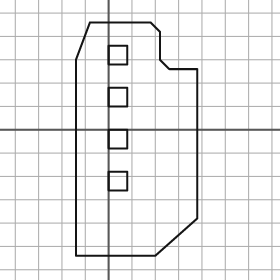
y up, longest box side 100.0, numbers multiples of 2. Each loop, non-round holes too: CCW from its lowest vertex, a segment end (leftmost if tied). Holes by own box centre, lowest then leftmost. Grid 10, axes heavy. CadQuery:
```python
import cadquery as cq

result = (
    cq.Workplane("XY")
    .moveTo(-14.0, -54.0)
    .lineTo(20.0, -54.0)
    .lineTo(38.0, -38.0)
    .lineTo(38.0, 26.0)
    .lineTo(26.0, 26.0)
    .lineTo(22.0, 30.0)
    .lineTo(22.0, 42.0)
    .lineTo(18.0, 46.0)
    .lineTo(-8.0, 46.0)
    .lineTo(-14.0, 30.0)
    .close()
    .moveTo(0.0, -26.0)
    .lineTo(8.0, -26.0)
    .lineTo(8.0, -18.0)
    .lineTo(0.0, -18.0)
    .close()
    .moveTo(0.0, -8.0)
    .lineTo(8.0, -8.0)
    .lineTo(8.0, 0.0)
    .lineTo(0.0, 0.0)
    .close()
    .moveTo(0.0, 10.0)
    .lineTo(8.0, 10.0)
    .lineTo(8.0, 18.0)
    .lineTo(0.0, 18.0)
    .close()
    .moveTo(0.0, 28.0)
    .lineTo(8.0, 28.0)
    .lineTo(8.0, 36.0)
    .lineTo(0.0, 36.0)
    .close()
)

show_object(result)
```